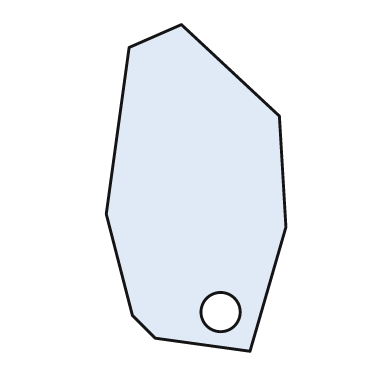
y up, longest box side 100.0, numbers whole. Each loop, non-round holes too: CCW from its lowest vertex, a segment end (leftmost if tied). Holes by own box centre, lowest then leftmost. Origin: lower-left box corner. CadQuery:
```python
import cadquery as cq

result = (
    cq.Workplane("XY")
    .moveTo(44.0, 0.0)
    .lineTo(55.0, 38.0)
    .lineTo(53.0, 72.0)
    .lineTo(23.0, 100.0)
    .lineTo(7.0, 93.0)
    .lineTo(0.0, 42.0)
    .lineTo(8.0, 11.0)
    .lineTo(15.0, 4.0)
    .close()
    .moveTo(35.0, 12.0)
    .circle(6.0)
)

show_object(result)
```